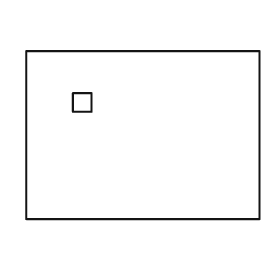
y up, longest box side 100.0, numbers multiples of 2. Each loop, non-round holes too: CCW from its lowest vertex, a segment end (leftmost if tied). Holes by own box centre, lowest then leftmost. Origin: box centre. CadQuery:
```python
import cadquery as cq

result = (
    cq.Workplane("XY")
    .moveTo(-50.0, -36.0)
    .lineTo(50.0, -36.0)
    .lineTo(50.0, 36.0)
    .lineTo(-50.0, 36.0)
    .close()
    .moveTo(-30.0, 10.0)
    .lineTo(-22.0, 10.0)
    .lineTo(-22.0, 18.0)
    .lineTo(-30.0, 18.0)
    .close()
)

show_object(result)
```